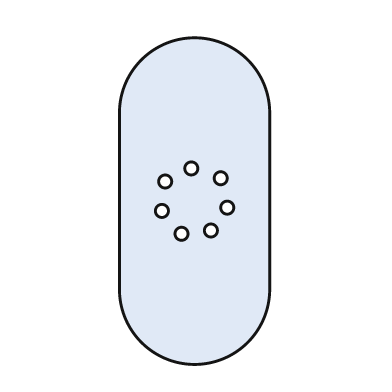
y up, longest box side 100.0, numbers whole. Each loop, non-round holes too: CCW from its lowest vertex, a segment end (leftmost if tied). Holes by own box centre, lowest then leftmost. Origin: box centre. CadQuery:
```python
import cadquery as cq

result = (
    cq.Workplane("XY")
    .moveTo(-23.0, -27.0)
    .threePointArc((0.0, -50.0), (23.0, -27.0))
    .lineTo(23.0, 27.0)
    .threePointArc((0.0, 50.0), (-23.0, 27.0))
    .close()
    .moveTo(-4.0, -10.0)
    .circle(2.0)
    .moveTo(5.0, -9.0)
    .circle(2.0)
    .moveTo(-10.0, -3.0)
    .circle(2.0)
    .moveTo(10.0, -2.0)
    .circle(2.0)
    .moveTo(-9.0, 6.0)
    .circle(2.0)
    .moveTo(8.0, 7.0)
    .circle(2.0)
    .moveTo(-1.0, 10.0)
    .circle(2.0)
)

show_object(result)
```